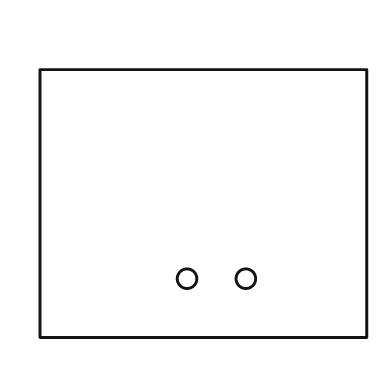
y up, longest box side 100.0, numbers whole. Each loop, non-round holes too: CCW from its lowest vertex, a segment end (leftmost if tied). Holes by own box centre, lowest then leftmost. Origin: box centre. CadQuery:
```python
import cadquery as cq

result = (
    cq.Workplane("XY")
    .moveTo(-50.0, -41.0)
    .lineTo(50.0, -41.0)
    .lineTo(50.0, 41.0)
    .lineTo(-50.0, 41.0)
    .close()
    .moveTo(-5.0, -23.0)
    .circle(3.0)
    .moveTo(13.0, -23.0)
    .circle(3.0)
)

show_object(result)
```